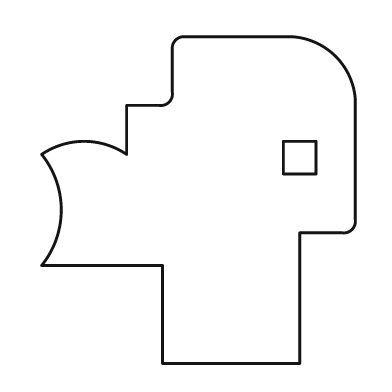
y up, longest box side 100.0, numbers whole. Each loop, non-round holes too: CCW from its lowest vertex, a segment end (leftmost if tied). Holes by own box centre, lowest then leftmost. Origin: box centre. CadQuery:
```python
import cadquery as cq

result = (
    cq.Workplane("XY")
    .moveTo(-11.0, -50.0)
    .lineTo(31.0, -50.0)
    .lineTo(31.0, -10.0)
    .lineTo(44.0, -10.0)
    .threePointArc((47.0, -9.0), (48.0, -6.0))
    .lineTo(48.0, 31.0)
    .threePointArc((42.0, 44.0), (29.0, 50.0))
    .lineTo(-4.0, 50.0)
    .threePointArc((-7.0, 49.0), (-8.0, 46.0))
    .lineTo(-8.0, 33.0)
    .threePointArc((-9.0, 30.0), (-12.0, 29.0))
    .lineTo(-22.0, 29.0)
    .lineTo(-22.0, 14.0)
    .threePointArc((-35.0, 18.0), (-48.0, 14.0))
    .threePointArc((-42.0, -3.0), (-48.0, -20.0))
    .lineTo(-11.0, -20.0)
    .close()
    .moveTo(26.0, 8.0)
    .lineTo(36.0, 8.0)
    .lineTo(36.0, 18.0)
    .lineTo(26.0, 18.0)
    .close()
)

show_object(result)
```